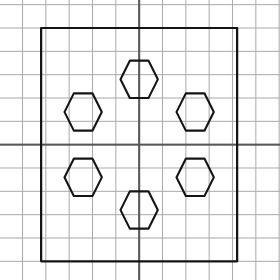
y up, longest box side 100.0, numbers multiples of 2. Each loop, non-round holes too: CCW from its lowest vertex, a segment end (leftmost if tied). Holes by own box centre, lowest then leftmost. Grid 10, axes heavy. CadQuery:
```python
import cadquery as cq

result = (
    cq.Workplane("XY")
    .moveTo(-42.0, -50.0)
    .lineTo(42.0, -50.0)
    .lineTo(42.0, 50.0)
    .lineTo(-42.0, 50.0)
    .close()
    .moveTo(-4.0, -36.0)
    .lineTo(4.0, -36.0)
    .lineTo(8.0, -28.0)
    .lineTo(4.0, -20.0)
    .lineTo(-4.0, -20.0)
    .lineTo(-8.0, -28.0)
    .close()
    .moveTo(-28.0, -22.0)
    .lineTo(-20.0, -22.0)
    .lineTo(-16.0, -14.0)
    .lineTo(-20.0, -6.0)
    .lineTo(-28.0, -6.0)
    .lineTo(-32.0, -14.0)
    .close()
    .moveTo(20.0, -22.0)
    .lineTo(28.0, -22.0)
    .lineTo(32.0, -14.0)
    .lineTo(28.0, -6.0)
    .lineTo(20.0, -6.0)
    .lineTo(16.0, -14.0)
    .close()
    .moveTo(-28.0, 6.0)
    .lineTo(-20.0, 6.0)
    .lineTo(-16.0, 14.0)
    .lineTo(-20.0, 22.0)
    .lineTo(-28.0, 22.0)
    .lineTo(-32.0, 14.0)
    .close()
    .moveTo(20.0, 6.0)
    .lineTo(28.0, 6.0)
    .lineTo(32.0, 14.0)
    .lineTo(28.0, 22.0)
    .lineTo(20.0, 22.0)
    .lineTo(16.0, 14.0)
    .close()
    .moveTo(-4.0, 20.0)
    .lineTo(4.0, 20.0)
    .lineTo(8.0, 28.0)
    .lineTo(4.0, 36.0)
    .lineTo(-4.0, 36.0)
    .lineTo(-8.0, 28.0)
    .close()
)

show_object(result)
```